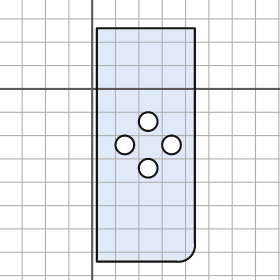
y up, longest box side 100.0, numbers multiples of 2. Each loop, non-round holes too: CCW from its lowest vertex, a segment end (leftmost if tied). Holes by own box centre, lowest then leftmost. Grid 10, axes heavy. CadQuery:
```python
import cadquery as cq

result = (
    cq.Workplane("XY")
    .moveTo(2.0, -74.0)
    .lineTo(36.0, -74.0)
    .threePointArc((42.0, -72.0), (44.0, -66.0))
    .lineTo(44.0, 26.0)
    .lineTo(2.0, 26.0)
    .close()
    .moveTo(24.0, -34.0)
    .circle(4.0)
    .moveTo(14.0, -24.0)
    .circle(4.0)
    .moveTo(34.0, -24.0)
    .circle(4.0)
    .moveTo(24.0, -14.0)
    .circle(4.0)
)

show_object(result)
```